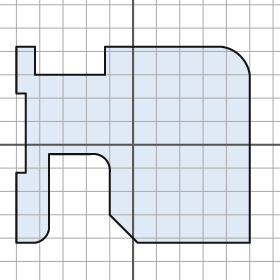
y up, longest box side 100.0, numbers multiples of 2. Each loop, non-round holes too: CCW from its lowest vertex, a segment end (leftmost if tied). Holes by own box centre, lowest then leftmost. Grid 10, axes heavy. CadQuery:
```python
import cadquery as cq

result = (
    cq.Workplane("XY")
    .moveTo(-50.0, -42.0)
    .lineTo(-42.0, -42.0)
    .threePointArc((-38.0, -40.0), (-36.0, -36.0))
    .lineTo(-36.0, -4.0)
    .lineTo(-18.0, -4.0)
    .threePointArc((-12.0, -6.0), (-10.0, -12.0))
    .lineTo(-10.0, -30.0)
    .lineTo(2.0, -42.0)
    .lineTo(50.0, -42.0)
    .lineTo(50.0, 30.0)
    .threePointArc((46.0, 38.0), (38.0, 42.0))
    .lineTo(-12.0, 42.0)
    .lineTo(-12.0, 30.0)
    .lineTo(-42.0, 30.0)
    .lineTo(-42.0, 42.0)
    .lineTo(-50.0, 42.0)
    .lineTo(-50.0, 22.0)
    .lineTo(-46.0, 22.0)
    .lineTo(-46.0, -12.0)
    .lineTo(-50.0, -12.0)
    .close()
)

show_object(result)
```